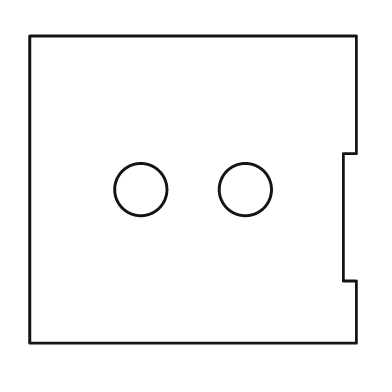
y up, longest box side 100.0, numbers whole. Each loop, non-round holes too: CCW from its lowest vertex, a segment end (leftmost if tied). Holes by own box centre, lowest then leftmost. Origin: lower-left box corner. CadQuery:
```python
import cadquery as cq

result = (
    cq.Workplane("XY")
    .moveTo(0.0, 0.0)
    .lineTo(100.0, 0.0)
    .lineTo(100.0, 19.0)
    .lineTo(96.0, 19.0)
    .lineTo(96.0, 58.0)
    .lineTo(100.0, 58.0)
    .lineTo(100.0, 94.0)
    .lineTo(0.0, 94.0)
    .close()
    .moveTo(34.0, 47.0)
    .circle(8.0)
    .moveTo(66.0, 47.0)
    .circle(8.0)
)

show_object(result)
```